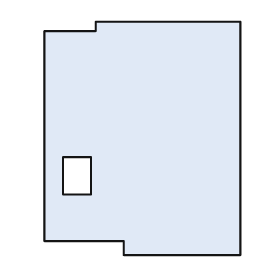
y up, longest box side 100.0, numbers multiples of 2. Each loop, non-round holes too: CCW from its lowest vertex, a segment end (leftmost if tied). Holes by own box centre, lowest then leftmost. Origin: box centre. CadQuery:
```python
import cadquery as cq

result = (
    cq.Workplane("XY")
    .moveTo(-8.0, -50.0)
    .lineTo(42.0, -50.0)
    .lineTo(42.0, 50.0)
    .lineTo(-20.0, 50.0)
    .lineTo(-20.0, 46.0)
    .lineTo(-42.0, 46.0)
    .lineTo(-42.0, -44.0)
    .lineTo(-8.0, -44.0)
    .close()
    .moveTo(-34.0, -24.0)
    .lineTo(-22.0, -24.0)
    .lineTo(-22.0, -8.0)
    .lineTo(-34.0, -8.0)
    .close()
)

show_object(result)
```